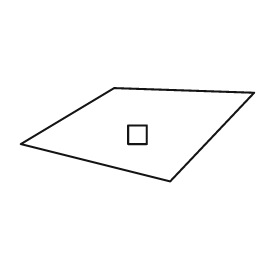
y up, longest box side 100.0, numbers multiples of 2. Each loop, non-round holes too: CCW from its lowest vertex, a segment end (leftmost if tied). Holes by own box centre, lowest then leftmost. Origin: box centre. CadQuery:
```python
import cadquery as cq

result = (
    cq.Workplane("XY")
    .moveTo(14.0, -20.0)
    .lineTo(50.0, 18.0)
    .lineTo(-10.0, 20.0)
    .lineTo(-50.0, -4.0)
    .close()
    .moveTo(-4.0, -4.0)
    .lineTo(4.0, -4.0)
    .lineTo(4.0, 4.0)
    .lineTo(-4.0, 4.0)
    .close()
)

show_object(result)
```